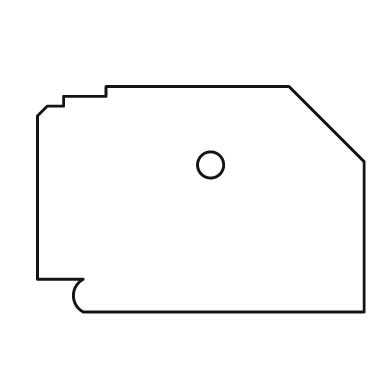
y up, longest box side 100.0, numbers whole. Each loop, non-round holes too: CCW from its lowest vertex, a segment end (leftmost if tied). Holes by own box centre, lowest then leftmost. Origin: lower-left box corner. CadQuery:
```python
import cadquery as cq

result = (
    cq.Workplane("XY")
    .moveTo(14.0, 0.0)
    .lineTo(100.0, 0.0)
    .lineTo(100.0, 46.0)
    .lineTo(77.0, 69.0)
    .lineTo(21.0, 69.0)
    .lineTo(21.0, 66.0)
    .lineTo(8.0, 66.0)
    .lineTo(8.0, 63.0)
    .lineTo(3.0, 63.0)
    .lineTo(0.0, 60.0)
    .lineTo(0.0, 10.0)
    .lineTo(14.0, 10.0)
    .threePointArc((11.0, 5.0), (14.0, 0.0))
    .close()
    .moveTo(53.0, 45.0)
    .circle(4.0)
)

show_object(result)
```